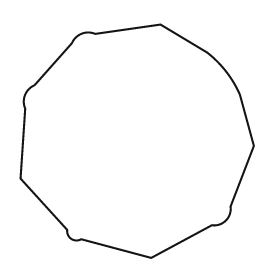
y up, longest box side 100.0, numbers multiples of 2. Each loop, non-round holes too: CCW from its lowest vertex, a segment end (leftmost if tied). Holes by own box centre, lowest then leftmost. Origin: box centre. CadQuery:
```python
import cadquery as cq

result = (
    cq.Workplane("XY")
    .moveTo(6.0, -50.0)
    .lineTo(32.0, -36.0)
    .threePointArc((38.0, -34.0), (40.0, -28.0))
    .lineTo(50.0, -2.0)
    .lineTo(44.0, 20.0)
    .threePointArc((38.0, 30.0), (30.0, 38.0))
    .lineTo(10.0, 50.0)
    .lineTo(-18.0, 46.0)
    .threePointArc((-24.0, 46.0), (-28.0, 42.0))
    .lineTo(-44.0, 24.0)
    .threePointArc((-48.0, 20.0), (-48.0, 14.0))
    .lineTo(-50.0, -16.0)
    .lineTo(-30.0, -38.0)
    .threePointArc((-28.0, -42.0), (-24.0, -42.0))
    .close()
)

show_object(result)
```